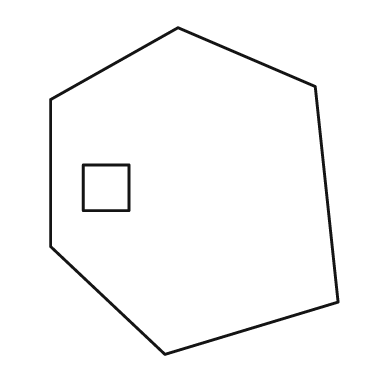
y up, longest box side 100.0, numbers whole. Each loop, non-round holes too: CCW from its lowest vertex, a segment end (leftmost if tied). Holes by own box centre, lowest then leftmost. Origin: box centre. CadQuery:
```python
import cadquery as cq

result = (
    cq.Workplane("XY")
    .moveTo(-9.0, -50.0)
    .lineTo(44.0, -34.0)
    .lineTo(37.0, 32.0)
    .lineTo(-5.0, 50.0)
    .lineTo(-44.0, 28.0)
    .lineTo(-44.0, -17.0)
    .close()
    .moveTo(-34.0, -6.0)
    .lineTo(-20.0, -6.0)
    .lineTo(-20.0, 8.0)
    .lineTo(-34.0, 8.0)
    .close()
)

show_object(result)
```